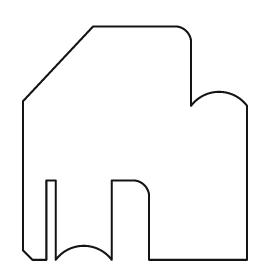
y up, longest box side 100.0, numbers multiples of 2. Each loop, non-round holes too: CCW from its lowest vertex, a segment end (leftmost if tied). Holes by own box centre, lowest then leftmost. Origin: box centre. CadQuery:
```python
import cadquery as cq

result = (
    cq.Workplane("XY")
    .moveTo(-44.0, -50.0)
    .lineTo(-38.0, -50.0)
    .lineTo(-38.0, -16.0)
    .lineTo(-34.0, -16.0)
    .lineTo(-34.0, -50.0)
    .threePointArc((-22.0, -44.0), (-10.0, -50.0))
    .lineTo(-10.0, -16.0)
    .lineTo(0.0, -16.0)
    .threePointArc((4.0, -18.0), (6.0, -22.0))
    .lineTo(6.0, -50.0)
    .lineTo(48.0, -50.0)
    .lineTo(48.0, 16.0)
    .threePointArc((36.0, 22.0), (24.0, 16.0))
    .lineTo(24.0, 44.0)
    .threePointArc((22.0, 48.0), (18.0, 50.0))
    .lineTo(-18.0, 50.0)
    .lineTo(-48.0, 18.0)
    .lineTo(-48.0, -46.0)
    .close()
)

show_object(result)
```